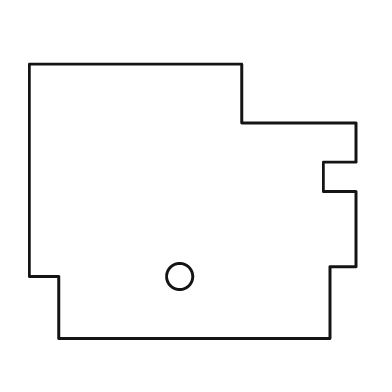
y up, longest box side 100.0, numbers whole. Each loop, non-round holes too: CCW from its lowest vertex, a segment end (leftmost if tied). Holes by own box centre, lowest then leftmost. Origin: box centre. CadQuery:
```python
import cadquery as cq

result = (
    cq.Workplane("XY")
    .moveTo(-41.0, -42.0)
    .lineTo(42.0, -42.0)
    .lineTo(42.0, -20.0)
    .lineTo(50.0, -20.0)
    .lineTo(50.0, 3.0)
    .lineTo(40.0, 3.0)
    .lineTo(40.0, 12.0)
    .lineTo(50.0, 12.0)
    .lineTo(50.0, 24.0)
    .lineTo(15.0, 24.0)
    .lineTo(15.0, 42.0)
    .lineTo(-50.0, 42.0)
    .lineTo(-50.0, -23.0)
    .lineTo(-41.0, -23.0)
    .close()
    .moveTo(-4.0, -23.0)
    .circle(4.0)
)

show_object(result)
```